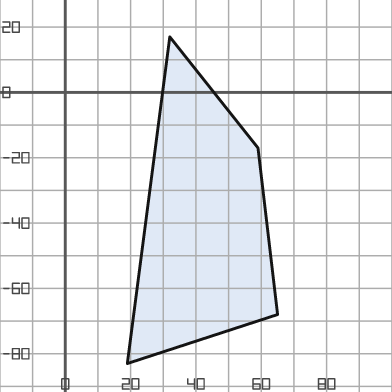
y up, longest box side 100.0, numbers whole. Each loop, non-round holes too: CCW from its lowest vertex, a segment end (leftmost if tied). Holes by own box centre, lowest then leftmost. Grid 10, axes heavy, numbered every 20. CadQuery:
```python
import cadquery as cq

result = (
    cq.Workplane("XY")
    .moveTo(19.0, -83.0)
    .lineTo(65.0, -68.0)
    .lineTo(59.0, -17.0)
    .lineTo(32.0, 17.0)
    .close()
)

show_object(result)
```